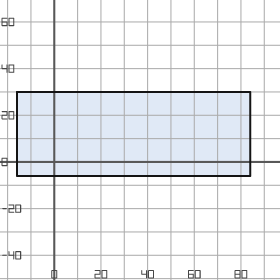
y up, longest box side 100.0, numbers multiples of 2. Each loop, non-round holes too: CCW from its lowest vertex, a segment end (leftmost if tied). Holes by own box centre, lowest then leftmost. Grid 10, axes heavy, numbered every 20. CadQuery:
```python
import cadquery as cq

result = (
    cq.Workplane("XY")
    .moveTo(-16.0, -6.0)
    .lineTo(84.0, -6.0)
    .lineTo(84.0, 30.0)
    .lineTo(-16.0, 30.0)
    .close()
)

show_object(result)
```